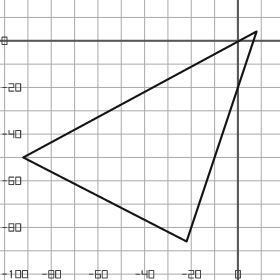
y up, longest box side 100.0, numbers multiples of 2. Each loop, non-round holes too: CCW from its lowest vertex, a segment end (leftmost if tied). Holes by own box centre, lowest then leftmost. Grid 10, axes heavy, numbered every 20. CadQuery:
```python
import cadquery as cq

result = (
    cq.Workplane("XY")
    .moveTo(-22.0, -86.0)
    .lineTo(8.0, 4.0)
    .lineTo(-92.0, -50.0)
    .close()
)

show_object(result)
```